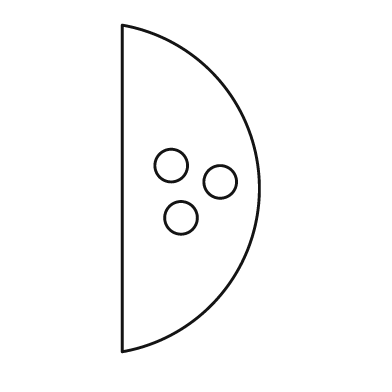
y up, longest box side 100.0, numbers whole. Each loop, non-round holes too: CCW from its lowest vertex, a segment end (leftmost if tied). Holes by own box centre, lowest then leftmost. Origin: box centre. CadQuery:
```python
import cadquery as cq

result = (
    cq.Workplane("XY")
    .moveTo(-21.0, -50.0)
    .threePointArc((21.0, 0.0), (-21.0, 50.0))
    .close()
    .moveTo(-3.0, -9.0)
    .circle(5.0)
    .moveTo(9.0, 2.0)
    .circle(5.0)
    .moveTo(-6.0, 7.0)
    .circle(5.0)
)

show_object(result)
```